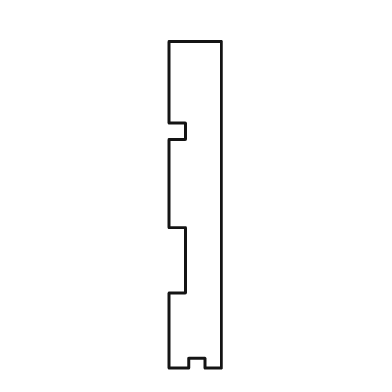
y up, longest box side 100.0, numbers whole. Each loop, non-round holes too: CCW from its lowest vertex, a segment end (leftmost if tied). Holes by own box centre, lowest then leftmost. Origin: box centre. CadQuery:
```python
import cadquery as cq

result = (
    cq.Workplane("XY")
    .moveTo(-8.0, -50.0)
    .lineTo(-2.0, -50.0)
    .lineTo(-2.0, -47.0)
    .lineTo(3.0, -47.0)
    .lineTo(3.0, -50.0)
    .lineTo(8.0, -50.0)
    .lineTo(8.0, 50.0)
    .lineTo(-8.0, 50.0)
    .lineTo(-8.0, 25.0)
    .lineTo(-3.0, 25.0)
    .lineTo(-3.0, 20.0)
    .lineTo(-8.0, 20.0)
    .lineTo(-8.0, -7.0)
    .lineTo(-3.0, -7.0)
    .lineTo(-3.0, -27.0)
    .lineTo(-8.0, -27.0)
    .close()
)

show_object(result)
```